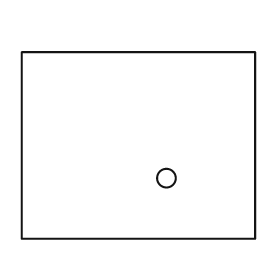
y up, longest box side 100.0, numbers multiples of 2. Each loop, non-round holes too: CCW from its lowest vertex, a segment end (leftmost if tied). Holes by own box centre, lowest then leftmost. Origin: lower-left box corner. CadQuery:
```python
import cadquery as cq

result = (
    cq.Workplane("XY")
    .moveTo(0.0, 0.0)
    .lineTo(100.0, 0.0)
    .lineTo(100.0, 80.0)
    .lineTo(0.0, 80.0)
    .close()
    .moveTo(62.0, 26.0)
    .circle(4.0)
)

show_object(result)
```